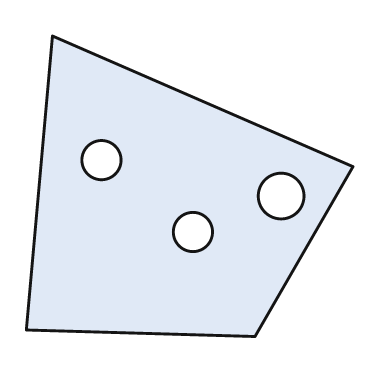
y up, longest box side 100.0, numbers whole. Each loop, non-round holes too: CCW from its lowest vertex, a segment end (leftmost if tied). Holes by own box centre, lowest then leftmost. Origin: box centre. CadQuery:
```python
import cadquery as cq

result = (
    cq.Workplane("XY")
    .moveTo(20.0, -46.0)
    .lineTo(50.0, 6.0)
    .lineTo(-42.0, 46.0)
    .lineTo(-50.0, -44.0)
    .close()
    .moveTo(1.0, -14.0)
    .circle(6.0)
    .moveTo(28.0, -3.0)
    .circle(7.0)
    .moveTo(-27.0, 8.0)
    .circle(6.0)
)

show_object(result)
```